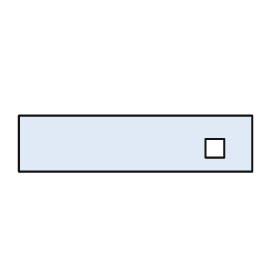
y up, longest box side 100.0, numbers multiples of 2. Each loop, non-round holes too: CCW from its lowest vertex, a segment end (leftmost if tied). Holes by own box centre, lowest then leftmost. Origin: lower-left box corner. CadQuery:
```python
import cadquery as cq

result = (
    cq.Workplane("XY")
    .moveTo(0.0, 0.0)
    .lineTo(100.0, 0.0)
    .lineTo(100.0, 24.0)
    .lineTo(0.0, 24.0)
    .close()
    .moveTo(80.0, 6.0)
    .lineTo(88.0, 6.0)
    .lineTo(88.0, 14.0)
    .lineTo(80.0, 14.0)
    .close()
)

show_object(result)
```